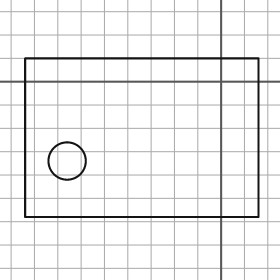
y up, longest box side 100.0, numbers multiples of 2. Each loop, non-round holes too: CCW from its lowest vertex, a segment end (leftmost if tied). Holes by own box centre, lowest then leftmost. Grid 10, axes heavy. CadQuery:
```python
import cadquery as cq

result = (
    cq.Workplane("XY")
    .moveTo(-84.0, -58.0)
    .lineTo(16.0, -58.0)
    .lineTo(16.0, 10.0)
    .lineTo(-84.0, 10.0)
    .close()
    .moveTo(-66.0, -34.0)
    .circle(8.0)
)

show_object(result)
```